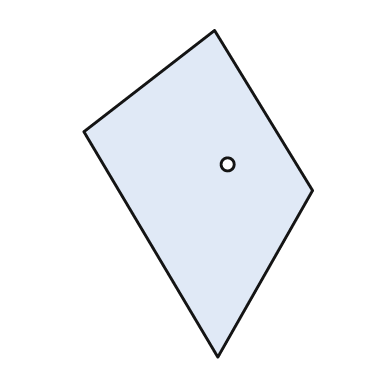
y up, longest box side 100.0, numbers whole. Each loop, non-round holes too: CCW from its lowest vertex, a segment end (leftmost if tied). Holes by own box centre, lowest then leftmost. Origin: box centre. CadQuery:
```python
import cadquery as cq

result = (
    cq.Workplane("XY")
    .moveTo(6.0, -50.0)
    .lineTo(35.0, 1.0)
    .lineTo(5.0, 50.0)
    .lineTo(-35.0, 19.0)
    .close()
    .moveTo(9.0, 9.0)
    .circle(2.0)
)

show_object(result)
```